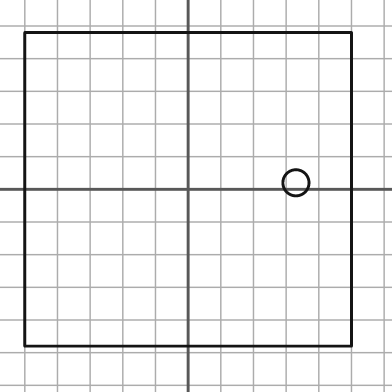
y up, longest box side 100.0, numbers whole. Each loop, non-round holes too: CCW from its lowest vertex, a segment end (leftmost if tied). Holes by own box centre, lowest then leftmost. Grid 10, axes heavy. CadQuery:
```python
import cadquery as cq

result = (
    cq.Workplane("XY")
    .moveTo(-50.0, -48.0)
    .lineTo(50.0, -48.0)
    .lineTo(50.0, 48.0)
    .lineTo(-50.0, 48.0)
    .close()
    .moveTo(33.0, 2.0)
    .circle(4.0)
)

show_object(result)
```